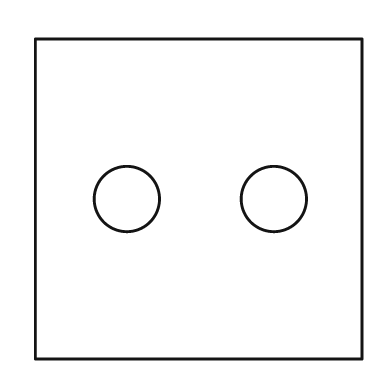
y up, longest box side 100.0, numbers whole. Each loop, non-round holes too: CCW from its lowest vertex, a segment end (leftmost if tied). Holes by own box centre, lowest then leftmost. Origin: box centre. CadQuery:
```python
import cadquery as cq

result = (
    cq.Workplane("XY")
    .moveTo(-50.0, -49.0)
    .lineTo(50.0, -49.0)
    .lineTo(50.0, 49.0)
    .lineTo(-50.0, 49.0)
    .close()
    .moveTo(-22.0, 0.0)
    .circle(10.0)
    .moveTo(23.0, 0.0)
    .circle(10.0)
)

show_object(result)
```